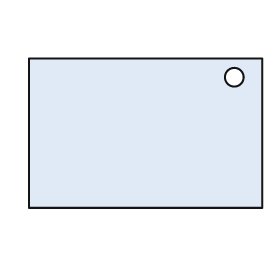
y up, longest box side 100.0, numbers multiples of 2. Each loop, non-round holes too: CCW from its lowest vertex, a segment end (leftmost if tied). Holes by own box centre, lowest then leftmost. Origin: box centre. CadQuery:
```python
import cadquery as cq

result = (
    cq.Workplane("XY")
    .moveTo(-50.0, -32.0)
    .lineTo(50.0, -32.0)
    .lineTo(50.0, 32.0)
    .lineTo(-50.0, 32.0)
    .close()
    .moveTo(38.0, 24.0)
    .circle(4.0)
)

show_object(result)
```